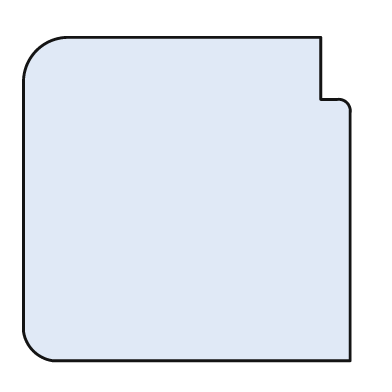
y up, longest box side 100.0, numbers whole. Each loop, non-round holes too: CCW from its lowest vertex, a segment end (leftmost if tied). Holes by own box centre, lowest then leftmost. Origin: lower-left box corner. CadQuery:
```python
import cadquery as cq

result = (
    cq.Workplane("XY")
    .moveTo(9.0, 0.0)
    .lineTo(100.0, 0.0)
    .lineTo(100.0, 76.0)
    .threePointArc((99.0, 79.0), (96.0, 80.0))
    .lineTo(91.0, 80.0)
    .lineTo(91.0, 99.0)
    .lineTo(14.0, 99.0)
    .threePointArc((4.0, 95.0), (0.0, 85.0))
    .lineTo(0.0, 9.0)
    .threePointArc((3.0, 3.0), (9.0, 0.0))
    .close()
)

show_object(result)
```